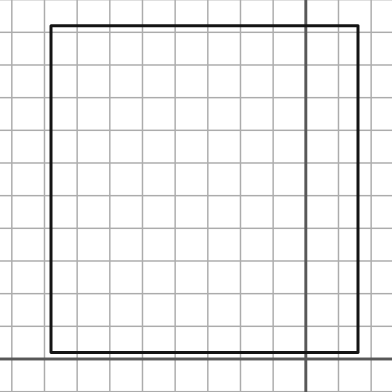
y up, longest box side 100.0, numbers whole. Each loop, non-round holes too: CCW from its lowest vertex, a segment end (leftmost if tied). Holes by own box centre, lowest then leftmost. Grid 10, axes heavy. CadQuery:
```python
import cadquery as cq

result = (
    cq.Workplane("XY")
    .moveTo(-78.0, 2.0)
    .lineTo(16.0, 2.0)
    .lineTo(16.0, 102.0)
    .lineTo(-78.0, 102.0)
    .close()
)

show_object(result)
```